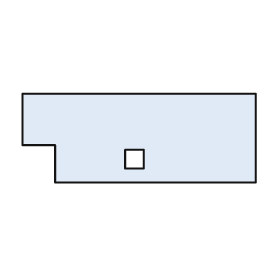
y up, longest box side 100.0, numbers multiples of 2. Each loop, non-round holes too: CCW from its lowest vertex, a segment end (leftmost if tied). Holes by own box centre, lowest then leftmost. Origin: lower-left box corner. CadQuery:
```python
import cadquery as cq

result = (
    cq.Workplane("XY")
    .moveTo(14.0, 0.0)
    .lineTo(100.0, 0.0)
    .lineTo(100.0, 38.0)
    .lineTo(0.0, 38.0)
    .lineTo(0.0, 16.0)
    .lineTo(14.0, 16.0)
    .close()
    .moveTo(44.0, 6.0)
    .lineTo(52.0, 6.0)
    .lineTo(52.0, 14.0)
    .lineTo(44.0, 14.0)
    .close()
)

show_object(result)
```